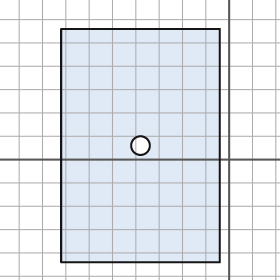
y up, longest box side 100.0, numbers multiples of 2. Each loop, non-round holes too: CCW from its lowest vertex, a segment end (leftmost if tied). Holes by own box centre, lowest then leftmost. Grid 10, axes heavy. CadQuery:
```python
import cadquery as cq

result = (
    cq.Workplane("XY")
    .moveTo(-72.0, -44.0)
    .lineTo(-4.0, -44.0)
    .lineTo(-4.0, 56.0)
    .lineTo(-72.0, 56.0)
    .close()
    .moveTo(-38.0, 6.0)
    .circle(4.0)
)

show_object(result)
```